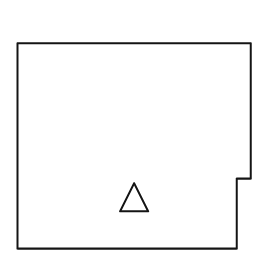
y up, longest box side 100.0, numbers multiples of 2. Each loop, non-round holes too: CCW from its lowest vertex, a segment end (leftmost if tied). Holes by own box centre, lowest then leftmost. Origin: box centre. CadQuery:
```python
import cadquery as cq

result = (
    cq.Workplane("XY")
    .moveTo(-50.0, -44.0)
    .lineTo(44.0, -44.0)
    .lineTo(44.0, -14.0)
    .lineTo(50.0, -14.0)
    .lineTo(50.0, 44.0)
    .lineTo(-50.0, 44.0)
    .close()
    .moveTo(-6.0, -28.0)
    .lineTo(6.0, -28.0)
    .lineTo(0.0, -16.0)
    .close()
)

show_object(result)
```